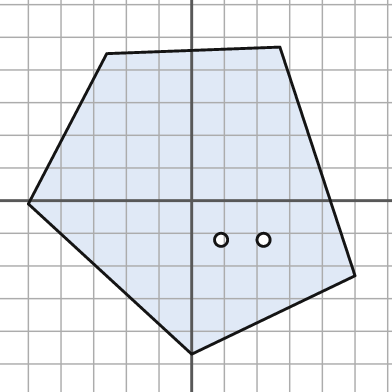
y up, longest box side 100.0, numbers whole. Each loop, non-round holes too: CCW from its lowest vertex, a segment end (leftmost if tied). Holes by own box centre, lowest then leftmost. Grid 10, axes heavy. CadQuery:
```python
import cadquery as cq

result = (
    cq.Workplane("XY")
    .moveTo(0.0, -47.0)
    .lineTo(50.0, -23.0)
    .lineTo(27.0, 47.0)
    .lineTo(-26.0, 45.0)
    .lineTo(-50.0, -1.0)
    .close()
    .moveTo(9.0, -12.0)
    .circle(2.0)
    .moveTo(22.0, -12.0)
    .circle(2.0)
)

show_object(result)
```